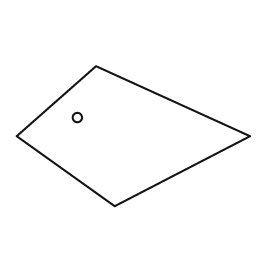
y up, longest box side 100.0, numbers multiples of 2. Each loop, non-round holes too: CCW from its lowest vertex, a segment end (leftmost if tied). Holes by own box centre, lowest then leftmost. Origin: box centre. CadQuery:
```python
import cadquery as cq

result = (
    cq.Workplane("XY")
    .moveTo(-8.0, -30.0)
    .lineTo(50.0, 0.0)
    .lineTo(-16.0, 30.0)
    .lineTo(-50.0, 0.0)
    .close()
    .moveTo(-24.0, 8.0)
    .circle(2.0)
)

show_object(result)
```